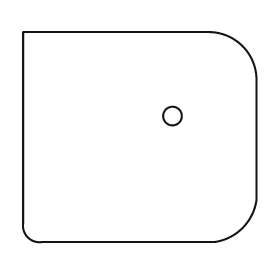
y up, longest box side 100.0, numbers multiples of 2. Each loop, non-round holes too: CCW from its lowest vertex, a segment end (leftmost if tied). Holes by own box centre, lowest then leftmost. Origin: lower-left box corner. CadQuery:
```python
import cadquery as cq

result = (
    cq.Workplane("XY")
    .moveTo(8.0, 0.0)
    .lineTo(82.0, 0.0)
    .threePointArc((94.0, 6.0), (100.0, 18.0))
    .lineTo(100.0, 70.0)
    .threePointArc((94.0, 84.0), (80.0, 90.0))
    .lineTo(0.0, 90.0)
    .lineTo(0.0, 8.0)
    .threePointArc((2.0, 2.0), (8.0, 0.0))
    .close()
    .moveTo(64.0, 54.0)
    .circle(4.0)
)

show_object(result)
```